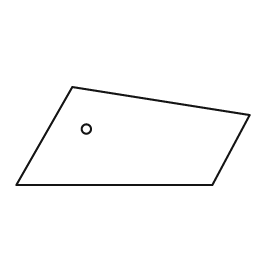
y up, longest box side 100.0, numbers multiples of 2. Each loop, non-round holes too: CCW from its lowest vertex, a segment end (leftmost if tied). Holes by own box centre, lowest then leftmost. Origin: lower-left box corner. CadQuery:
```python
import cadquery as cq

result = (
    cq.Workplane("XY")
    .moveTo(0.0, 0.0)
    .lineTo(84.0, 0.0)
    .lineTo(100.0, 30.0)
    .lineTo(24.0, 42.0)
    .close()
    .moveTo(30.0, 24.0)
    .circle(2.0)
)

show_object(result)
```